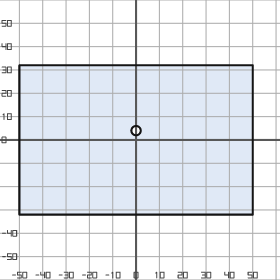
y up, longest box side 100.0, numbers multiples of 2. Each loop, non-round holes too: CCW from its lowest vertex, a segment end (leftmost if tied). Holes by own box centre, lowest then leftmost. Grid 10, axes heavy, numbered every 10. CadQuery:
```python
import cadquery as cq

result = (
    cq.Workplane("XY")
    .moveTo(-50.0, -32.0)
    .lineTo(50.0, -32.0)
    .lineTo(50.0, 32.0)
    .lineTo(-50.0, 32.0)
    .close()
    .moveTo(0.0, 4.0)
    .circle(2.0)
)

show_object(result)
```